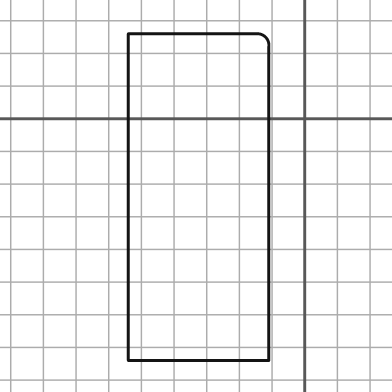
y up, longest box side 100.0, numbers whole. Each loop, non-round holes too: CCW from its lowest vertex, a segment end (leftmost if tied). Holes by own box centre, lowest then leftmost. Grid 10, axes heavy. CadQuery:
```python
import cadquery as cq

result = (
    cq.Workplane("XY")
    .moveTo(-54.0, -74.0)
    .lineTo(-11.0, -74.0)
    .lineTo(-11.0, 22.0)
    .threePointArc((-12.0, 25.0), (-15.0, 26.0))
    .lineTo(-54.0, 26.0)
    .close()
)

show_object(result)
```